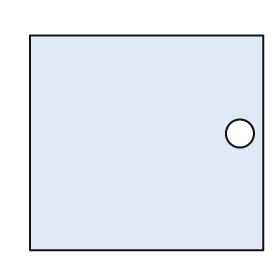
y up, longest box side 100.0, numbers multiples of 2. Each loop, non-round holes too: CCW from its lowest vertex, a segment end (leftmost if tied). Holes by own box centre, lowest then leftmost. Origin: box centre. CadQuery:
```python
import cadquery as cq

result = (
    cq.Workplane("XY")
    .moveTo(-50.0, -46.0)
    .lineTo(50.0, -46.0)
    .lineTo(50.0, 46.0)
    .lineTo(-50.0, 46.0)
    .close()
    .moveTo(40.0, 4.0)
    .circle(6.0)
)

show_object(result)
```